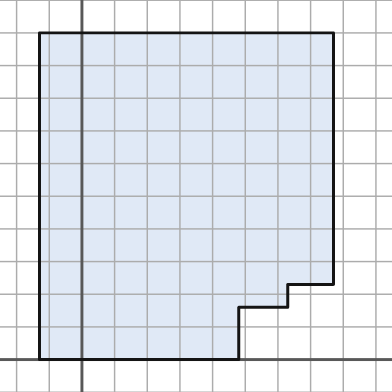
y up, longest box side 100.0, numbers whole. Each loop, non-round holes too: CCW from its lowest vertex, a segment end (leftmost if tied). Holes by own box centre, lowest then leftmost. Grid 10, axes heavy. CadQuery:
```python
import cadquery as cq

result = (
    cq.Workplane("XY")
    .moveTo(-13.0, 0.0)
    .lineTo(48.0, 0.0)
    .lineTo(48.0, 16.0)
    .lineTo(63.0, 16.0)
    .lineTo(63.0, 23.0)
    .lineTo(77.0, 23.0)
    .lineTo(77.0, 100.0)
    .lineTo(-13.0, 100.0)
    .close()
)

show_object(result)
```